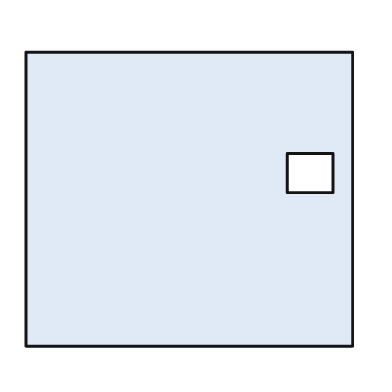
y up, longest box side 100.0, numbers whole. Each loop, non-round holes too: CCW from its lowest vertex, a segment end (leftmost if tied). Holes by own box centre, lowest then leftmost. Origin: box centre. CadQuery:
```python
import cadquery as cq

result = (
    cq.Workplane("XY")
    .moveTo(-50.0, -45.0)
    .lineTo(50.0, -45.0)
    .lineTo(50.0, 45.0)
    .lineTo(-50.0, 45.0)
    .close()
    .moveTo(30.0, 2.0)
    .lineTo(44.0, 2.0)
    .lineTo(44.0, 14.0)
    .lineTo(30.0, 14.0)
    .close()
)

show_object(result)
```